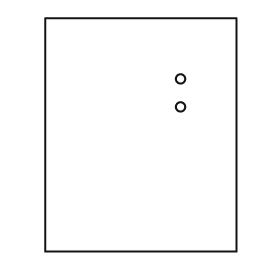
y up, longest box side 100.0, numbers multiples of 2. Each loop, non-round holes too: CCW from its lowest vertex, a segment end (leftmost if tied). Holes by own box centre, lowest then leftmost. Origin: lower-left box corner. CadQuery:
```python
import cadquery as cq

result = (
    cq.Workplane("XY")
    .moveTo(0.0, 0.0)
    .lineTo(82.0, 0.0)
    .lineTo(82.0, 100.0)
    .lineTo(0.0, 100.0)
    .close()
    .moveTo(58.0, 62.0)
    .circle(2.0)
    .moveTo(58.0, 74.0)
    .circle(2.0)
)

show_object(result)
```